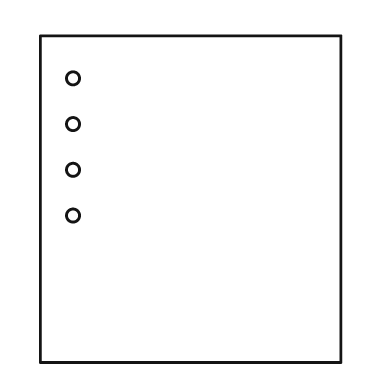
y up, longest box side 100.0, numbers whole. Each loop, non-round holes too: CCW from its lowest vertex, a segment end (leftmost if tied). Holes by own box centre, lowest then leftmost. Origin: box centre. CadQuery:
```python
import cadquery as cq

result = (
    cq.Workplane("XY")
    .moveTo(-46.0, -50.0)
    .lineTo(46.0, -50.0)
    .lineTo(46.0, 50.0)
    .lineTo(-46.0, 50.0)
    .close()
    .moveTo(-36.0, -5.0)
    .circle(2.0)
    .moveTo(-36.0, 9.0)
    .circle(2.0)
    .moveTo(-36.0, 23.0)
    .circle(2.0)
    .moveTo(-36.0, 37.0)
    .circle(2.0)
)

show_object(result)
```